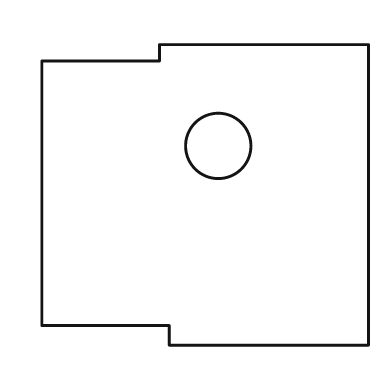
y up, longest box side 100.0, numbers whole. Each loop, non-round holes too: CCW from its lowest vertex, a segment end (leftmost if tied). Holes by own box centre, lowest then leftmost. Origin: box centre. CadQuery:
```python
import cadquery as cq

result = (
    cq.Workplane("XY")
    .moveTo(-11.0, -46.0)
    .lineTo(50.0, -46.0)
    .lineTo(50.0, 46.0)
    .lineTo(-14.0, 46.0)
    .lineTo(-14.0, 41.0)
    .lineTo(-50.0, 41.0)
    .lineTo(-50.0, -40.0)
    .lineTo(-11.0, -40.0)
    .close()
    .moveTo(4.0, 15.0)
    .circle(10.0)
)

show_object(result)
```